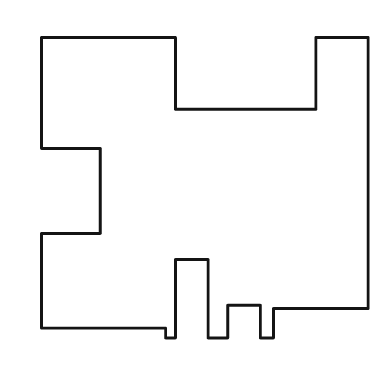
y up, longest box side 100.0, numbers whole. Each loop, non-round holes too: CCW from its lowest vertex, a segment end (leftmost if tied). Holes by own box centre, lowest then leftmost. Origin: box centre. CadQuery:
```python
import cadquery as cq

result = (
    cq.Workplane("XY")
    .moveTo(-12.0, -46.0)
    .lineTo(-9.0, -46.0)
    .lineTo(-9.0, -22.0)
    .lineTo(1.0, -22.0)
    .lineTo(1.0, -46.0)
    .lineTo(7.0, -46.0)
    .lineTo(7.0, -36.0)
    .lineTo(17.0, -36.0)
    .lineTo(17.0, -46.0)
    .lineTo(21.0, -46.0)
    .lineTo(21.0, -37.0)
    .lineTo(50.0, -37.0)
    .lineTo(50.0, 46.0)
    .lineTo(34.0, 46.0)
    .lineTo(34.0, 24.0)
    .lineTo(-9.0, 24.0)
    .lineTo(-9.0, 46.0)
    .lineTo(-50.0, 46.0)
    .lineTo(-50.0, 12.0)
    .lineTo(-32.0, 12.0)
    .lineTo(-32.0, -14.0)
    .lineTo(-50.0, -14.0)
    .lineTo(-50.0, -43.0)
    .lineTo(-12.0, -43.0)
    .close()
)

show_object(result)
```